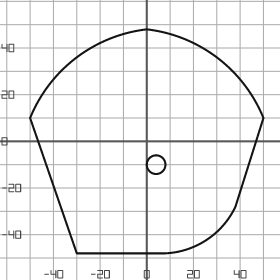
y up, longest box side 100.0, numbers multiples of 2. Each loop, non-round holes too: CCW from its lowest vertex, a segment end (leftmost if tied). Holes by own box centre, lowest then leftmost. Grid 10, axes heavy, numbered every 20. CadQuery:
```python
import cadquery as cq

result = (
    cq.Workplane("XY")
    .moveTo(-30.0, -48.0)
    .lineTo(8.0, -48.0)
    .threePointArc((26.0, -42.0), (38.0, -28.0))
    .lineTo(50.0, 10.0)
    .threePointArc((30.0, 36.0), (0.0, 48.0))
    .threePointArc((-30.0, 36.0), (-50.0, 10.0))
    .close()
    .moveTo(4.0, -10.0)
    .circle(4.0)
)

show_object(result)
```